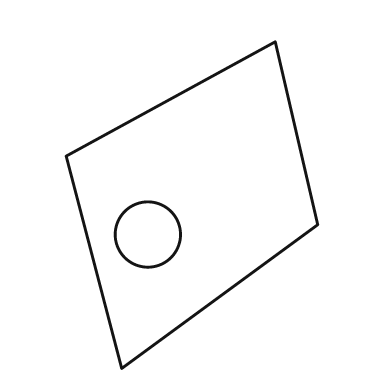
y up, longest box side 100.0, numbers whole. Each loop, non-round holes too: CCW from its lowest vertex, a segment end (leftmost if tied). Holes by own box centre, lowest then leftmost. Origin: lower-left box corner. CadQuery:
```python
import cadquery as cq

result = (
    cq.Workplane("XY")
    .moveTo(17.0, 0.0)
    .lineTo(77.0, 44.0)
    .lineTo(64.0, 100.0)
    .lineTo(0.0, 65.0)
    .close()
    .moveTo(25.0, 41.0)
    .circle(10.0)
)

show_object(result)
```